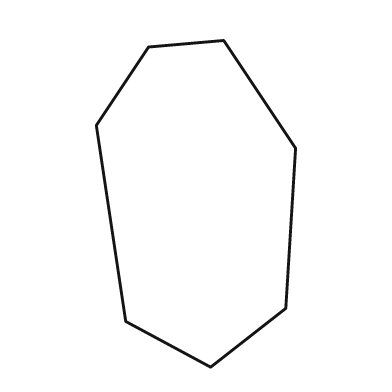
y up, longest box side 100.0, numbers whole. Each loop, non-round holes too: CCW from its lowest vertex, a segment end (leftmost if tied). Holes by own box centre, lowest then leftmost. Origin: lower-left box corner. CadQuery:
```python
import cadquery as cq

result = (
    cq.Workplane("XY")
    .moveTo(35.0, 0.0)
    .lineTo(58.0, 18.0)
    .lineTo(61.0, 67.0)
    .lineTo(39.0, 100.0)
    .lineTo(16.0, 98.0)
    .lineTo(0.0, 74.0)
    .lineTo(9.0, 14.0)
    .close()
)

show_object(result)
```